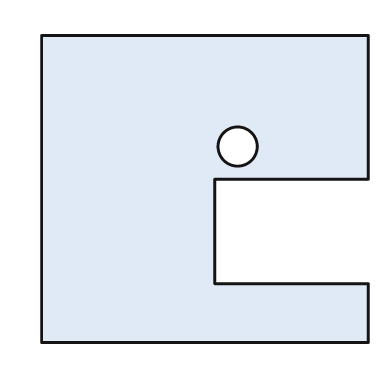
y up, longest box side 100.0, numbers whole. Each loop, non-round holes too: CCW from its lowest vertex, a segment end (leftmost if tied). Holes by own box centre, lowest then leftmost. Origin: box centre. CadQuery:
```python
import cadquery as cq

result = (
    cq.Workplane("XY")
    .moveTo(-50.0, -47.0)
    .lineTo(50.0, -47.0)
    .lineTo(50.0, -29.0)
    .lineTo(3.0, -29.0)
    .lineTo(3.0, 3.0)
    .lineTo(50.0, 3.0)
    .lineTo(50.0, 47.0)
    .lineTo(-50.0, 47.0)
    .close()
    .moveTo(10.0, 13.0)
    .circle(6.0)
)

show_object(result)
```